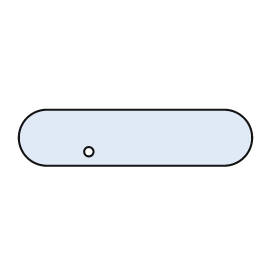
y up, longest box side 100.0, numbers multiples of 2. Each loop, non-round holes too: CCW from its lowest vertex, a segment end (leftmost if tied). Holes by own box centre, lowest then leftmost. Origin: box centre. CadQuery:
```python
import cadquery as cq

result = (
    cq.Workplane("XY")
    .moveTo(-38.0, -12.0)
    .lineTo(38.0, -12.0)
    .threePointArc((50.0, 0.0), (38.0, 12.0))
    .lineTo(-38.0, 12.0)
    .threePointArc((-50.0, 0.0), (-38.0, -12.0))
    .close()
    .moveTo(-20.0, -6.0)
    .circle(2.0)
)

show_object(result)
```